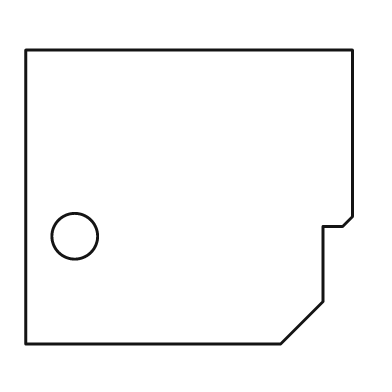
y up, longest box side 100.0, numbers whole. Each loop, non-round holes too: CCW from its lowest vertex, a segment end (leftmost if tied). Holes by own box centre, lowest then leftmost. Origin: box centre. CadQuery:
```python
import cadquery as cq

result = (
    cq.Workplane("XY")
    .moveTo(-50.0, -45.0)
    .lineTo(28.0, -45.0)
    .lineTo(41.0, -32.0)
    .lineTo(41.0, -9.0)
    .lineTo(47.0, -9.0)
    .lineTo(50.0, -6.0)
    .lineTo(50.0, 45.0)
    .lineTo(-50.0, 45.0)
    .close()
    .moveTo(-35.0, -12.0)
    .circle(7.0)
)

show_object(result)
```